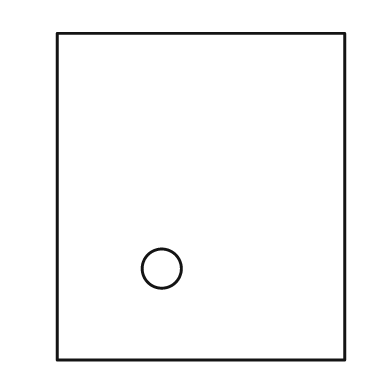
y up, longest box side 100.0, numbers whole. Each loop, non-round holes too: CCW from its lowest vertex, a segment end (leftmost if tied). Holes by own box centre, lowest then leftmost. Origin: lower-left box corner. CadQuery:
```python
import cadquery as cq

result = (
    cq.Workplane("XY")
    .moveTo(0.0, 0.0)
    .lineTo(88.0, 0.0)
    .lineTo(88.0, 100.0)
    .lineTo(0.0, 100.0)
    .close()
    .moveTo(32.0, 28.0)
    .circle(6.0)
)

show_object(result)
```